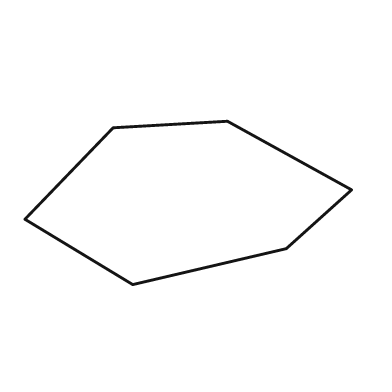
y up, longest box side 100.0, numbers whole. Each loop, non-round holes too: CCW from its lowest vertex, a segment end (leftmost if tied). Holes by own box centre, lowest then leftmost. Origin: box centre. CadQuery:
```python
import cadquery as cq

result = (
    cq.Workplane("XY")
    .moveTo(-17.0, -25.0)
    .lineTo(30.0, -14.0)
    .lineTo(50.0, 4.0)
    .lineTo(12.0, 25.0)
    .lineTo(-23.0, 23.0)
    .lineTo(-50.0, -5.0)
    .close()
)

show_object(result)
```